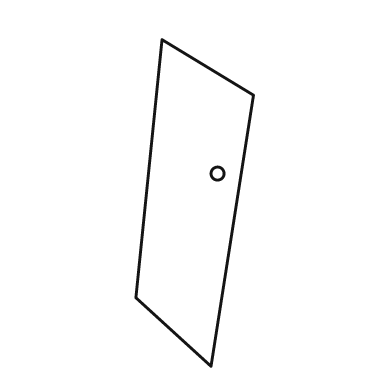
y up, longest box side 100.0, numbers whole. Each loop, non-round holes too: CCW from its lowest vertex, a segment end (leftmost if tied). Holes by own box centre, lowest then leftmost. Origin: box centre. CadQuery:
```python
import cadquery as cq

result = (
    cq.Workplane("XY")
    .moveTo(5.0, -50.0)
    .lineTo(18.0, 33.0)
    .lineTo(-10.0, 50.0)
    .lineTo(-18.0, -29.0)
    .close()
    .moveTo(7.0, 9.0)
    .circle(2.0)
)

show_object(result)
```